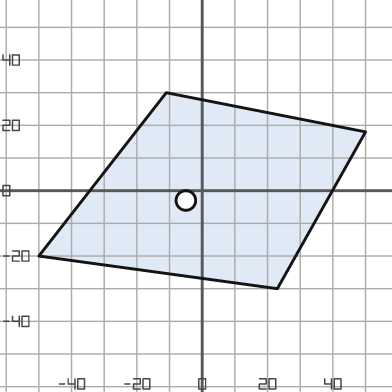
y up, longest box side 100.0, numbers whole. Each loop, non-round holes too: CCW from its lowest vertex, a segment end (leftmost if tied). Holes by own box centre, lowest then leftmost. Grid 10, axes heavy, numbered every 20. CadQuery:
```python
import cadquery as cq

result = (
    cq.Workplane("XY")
    .moveTo(23.0, -30.0)
    .lineTo(50.0, 18.0)
    .lineTo(-11.0, 30.0)
    .lineTo(-50.0, -20.0)
    .close()
    .moveTo(-5.0, -3.0)
    .circle(3.0)
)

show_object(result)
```